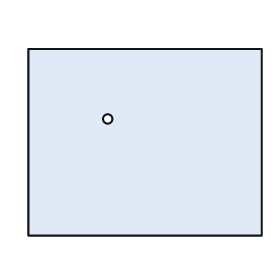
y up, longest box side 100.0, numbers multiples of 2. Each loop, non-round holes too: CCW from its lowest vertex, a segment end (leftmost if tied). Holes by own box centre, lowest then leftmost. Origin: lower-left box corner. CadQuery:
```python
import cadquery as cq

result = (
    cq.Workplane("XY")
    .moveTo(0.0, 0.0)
    .lineTo(100.0, 0.0)
    .lineTo(100.0, 80.0)
    .lineTo(0.0, 80.0)
    .close()
    .moveTo(34.0, 50.0)
    .circle(2.0)
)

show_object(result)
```